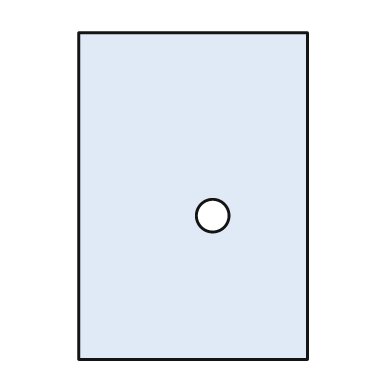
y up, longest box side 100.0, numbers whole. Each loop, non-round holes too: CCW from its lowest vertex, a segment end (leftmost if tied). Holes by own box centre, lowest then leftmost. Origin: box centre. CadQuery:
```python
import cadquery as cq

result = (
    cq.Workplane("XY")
    .moveTo(-35.0, -50.0)
    .lineTo(35.0, -50.0)
    .lineTo(35.0, 50.0)
    .lineTo(-35.0, 50.0)
    .close()
    .moveTo(6.0, -6.0)
    .circle(5.0)
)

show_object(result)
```